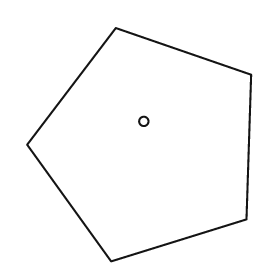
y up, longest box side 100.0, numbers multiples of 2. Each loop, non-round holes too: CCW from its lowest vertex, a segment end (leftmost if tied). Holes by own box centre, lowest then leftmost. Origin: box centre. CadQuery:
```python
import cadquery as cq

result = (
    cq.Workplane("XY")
    .moveTo(-12.0, -50.0)
    .lineTo(46.0, -32.0)
    .lineTo(48.0, 30.0)
    .lineTo(-10.0, 50.0)
    .lineTo(-48.0, 0.0)
    .close()
    .moveTo(2.0, 10.0)
    .circle(2.0)
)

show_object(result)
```